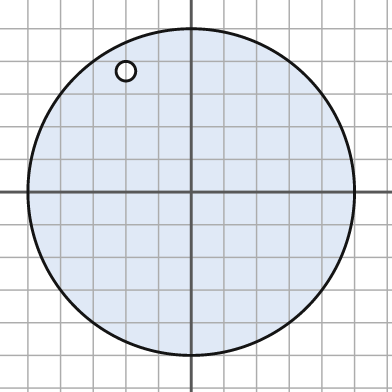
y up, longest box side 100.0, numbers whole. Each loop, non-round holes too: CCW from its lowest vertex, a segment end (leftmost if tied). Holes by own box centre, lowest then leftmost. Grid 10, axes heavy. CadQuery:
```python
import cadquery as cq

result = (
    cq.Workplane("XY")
    .moveTo(0.0, 0.0)
    .circle(50.0)
    .moveTo(-20.0, 37.0)
    .circle(3.0)
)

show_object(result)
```